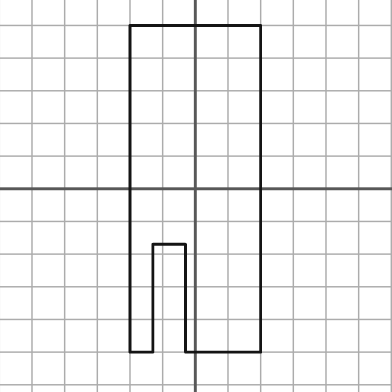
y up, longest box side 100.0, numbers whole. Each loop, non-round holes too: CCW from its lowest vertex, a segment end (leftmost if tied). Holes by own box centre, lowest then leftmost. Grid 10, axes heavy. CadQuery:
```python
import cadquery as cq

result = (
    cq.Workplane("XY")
    .moveTo(-20.0, -50.0)
    .lineTo(-13.0, -50.0)
    .lineTo(-13.0, -17.0)
    .lineTo(-3.0, -17.0)
    .lineTo(-3.0, -50.0)
    .lineTo(20.0, -50.0)
    .lineTo(20.0, 50.0)
    .lineTo(-20.0, 50.0)
    .close()
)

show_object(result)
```